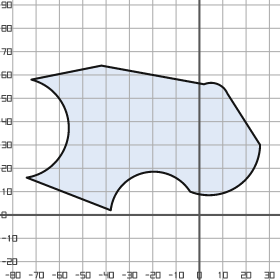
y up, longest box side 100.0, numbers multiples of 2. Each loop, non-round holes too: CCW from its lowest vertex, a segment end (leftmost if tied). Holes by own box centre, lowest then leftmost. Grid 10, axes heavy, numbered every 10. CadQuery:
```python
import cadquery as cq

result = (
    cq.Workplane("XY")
    .moveTo(-38.0, 2.0)
    .threePointArc((-24.0, 18.0), (-4.0, 10.0))
    .threePointArc((16.0, 12.0), (26.0, 30.0))
    .lineTo(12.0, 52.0)
    .threePointArc((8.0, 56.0), (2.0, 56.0))
    .lineTo(-42.0, 64.0)
    .lineTo(-72.0, 58.0)
    .threePointArc((-56.0, 36.0), (-74.0, 16.0))
    .close()
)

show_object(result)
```